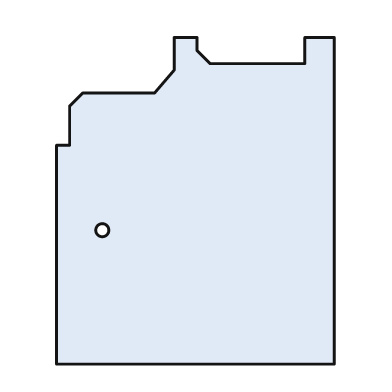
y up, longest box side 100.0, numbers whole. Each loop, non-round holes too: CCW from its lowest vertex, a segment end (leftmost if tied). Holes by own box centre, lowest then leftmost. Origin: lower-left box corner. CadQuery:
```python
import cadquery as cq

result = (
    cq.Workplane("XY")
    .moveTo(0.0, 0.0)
    .lineTo(85.0, 0.0)
    .lineTo(85.0, 100.0)
    .lineTo(76.0, 100.0)
    .lineTo(76.0, 92.0)
    .lineTo(47.0, 92.0)
    .lineTo(43.0, 96.0)
    .lineTo(43.0, 100.0)
    .lineTo(36.0, 100.0)
    .lineTo(36.0, 90.0)
    .lineTo(30.0, 83.0)
    .lineTo(8.0, 83.0)
    .lineTo(4.0, 79.0)
    .lineTo(4.0, 67.0)
    .lineTo(0.0, 67.0)
    .close()
    .moveTo(14.0, 41.0)
    .circle(2.0)
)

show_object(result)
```